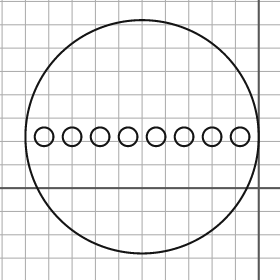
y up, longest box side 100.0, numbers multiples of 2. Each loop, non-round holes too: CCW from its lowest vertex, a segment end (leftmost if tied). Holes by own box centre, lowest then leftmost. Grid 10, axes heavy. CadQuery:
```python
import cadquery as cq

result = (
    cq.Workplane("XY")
    .moveTo(-50.0, 22.0)
    .circle(50.0)
    .moveTo(-92.0, 22.0)
    .circle(4.0)
    .moveTo(-80.0, 22.0)
    .circle(4.0)
    .moveTo(-68.0, 22.0)
    .circle(4.0)
    .moveTo(-56.0, 22.0)
    .circle(4.0)
    .moveTo(-44.0, 22.0)
    .circle(4.0)
    .moveTo(-32.0, 22.0)
    .circle(4.0)
    .moveTo(-20.0, 22.0)
    .circle(4.0)
    .moveTo(-8.0, 22.0)
    .circle(4.0)
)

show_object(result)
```